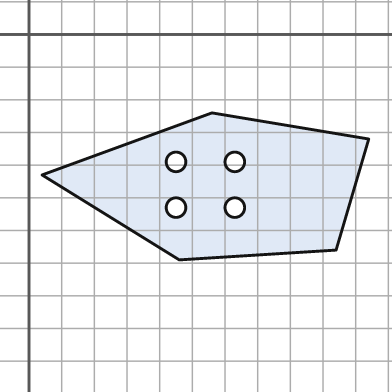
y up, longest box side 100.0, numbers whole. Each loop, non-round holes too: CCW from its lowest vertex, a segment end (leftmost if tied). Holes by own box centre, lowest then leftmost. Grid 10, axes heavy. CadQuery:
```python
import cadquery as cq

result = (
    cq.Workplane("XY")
    .moveTo(46.0, -69.0)
    .lineTo(94.0, -66.0)
    .lineTo(104.0, -32.0)
    .lineTo(56.0, -24.0)
    .lineTo(4.0, -43.0)
    .close()
    .moveTo(45.0, -53.0)
    .circle(3.0)
    .moveTo(63.0, -53.0)
    .circle(3.0)
    .moveTo(45.0, -39.0)
    .circle(3.0)
    .moveTo(63.0, -39.0)
    .circle(3.0)
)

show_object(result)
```